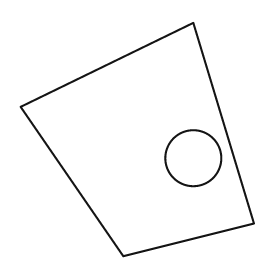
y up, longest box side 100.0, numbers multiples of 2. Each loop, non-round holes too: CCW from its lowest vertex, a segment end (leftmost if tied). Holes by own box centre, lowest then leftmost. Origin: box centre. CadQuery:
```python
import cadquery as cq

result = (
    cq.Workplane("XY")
    .moveTo(-6.0, -50.0)
    .lineTo(50.0, -36.0)
    .lineTo(24.0, 50.0)
    .lineTo(-50.0, 14.0)
    .close()
    .moveTo(24.0, -8.0)
    .circle(12.0)
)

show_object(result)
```